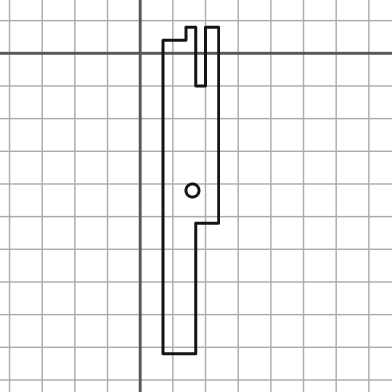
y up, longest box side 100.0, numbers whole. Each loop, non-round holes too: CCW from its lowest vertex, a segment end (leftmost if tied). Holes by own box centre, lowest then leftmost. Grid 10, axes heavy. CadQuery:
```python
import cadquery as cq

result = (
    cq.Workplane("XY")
    .moveTo(7.0, -92.0)
    .lineTo(17.0, -92.0)
    .lineTo(17.0, -52.0)
    .lineTo(24.0, -52.0)
    .lineTo(24.0, 8.0)
    .lineTo(20.0, 8.0)
    .lineTo(20.0, -10.0)
    .lineTo(17.0, -10.0)
    .lineTo(17.0, 8.0)
    .lineTo(14.0, 8.0)
    .lineTo(14.0, 4.0)
    .lineTo(7.0, 4.0)
    .close()
    .moveTo(16.0, -42.0)
    .circle(2.0)
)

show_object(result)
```